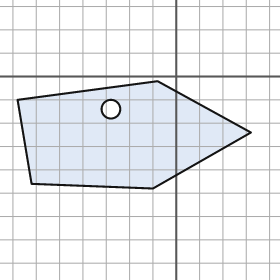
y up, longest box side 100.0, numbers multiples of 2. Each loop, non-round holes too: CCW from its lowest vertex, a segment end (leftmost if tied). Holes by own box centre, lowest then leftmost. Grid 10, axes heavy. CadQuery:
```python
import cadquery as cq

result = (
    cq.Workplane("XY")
    .moveTo(-10.0, -48.0)
    .lineTo(32.0, -24.0)
    .lineTo(-8.0, -2.0)
    .lineTo(-68.0, -10.0)
    .lineTo(-62.0, -46.0)
    .close()
    .moveTo(-28.0, -14.0)
    .circle(4.0)
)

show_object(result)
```